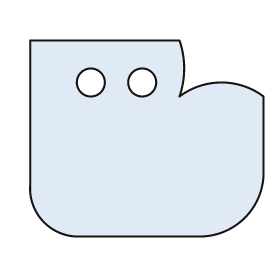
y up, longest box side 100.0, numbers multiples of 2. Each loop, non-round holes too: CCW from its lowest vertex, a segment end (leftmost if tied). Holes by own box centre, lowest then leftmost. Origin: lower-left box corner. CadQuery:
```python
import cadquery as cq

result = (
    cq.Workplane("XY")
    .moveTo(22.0, 0.0)
    .lineTo(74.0, 0.0)
    .threePointArc((92.0, 8.0), (100.0, 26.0))
    .lineTo(100.0, 60.0)
    .threePointArc((82.0, 66.0), (64.0, 60.0))
    .threePointArc((66.0, 72.0), (64.0, 84.0))
    .lineTo(0.0, 84.0)
    .lineTo(0.0, 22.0)
    .threePointArc((6.0, 6.0), (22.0, 0.0))
    .close()
    .moveTo(26.0, 66.0)
    .circle(6.0)
    .moveTo(48.0, 66.0)
    .circle(6.0)
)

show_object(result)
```